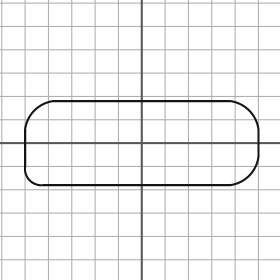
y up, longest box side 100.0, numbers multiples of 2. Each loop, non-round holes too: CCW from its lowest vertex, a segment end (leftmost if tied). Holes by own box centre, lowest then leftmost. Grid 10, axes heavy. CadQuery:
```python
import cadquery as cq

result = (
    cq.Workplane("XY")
    .moveTo(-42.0, -18.0)
    .lineTo(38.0, -18.0)
    .threePointArc((46.0, -14.0), (50.0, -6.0))
    .lineTo(50.0, 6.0)
    .threePointArc((46.0, 14.0), (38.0, 18.0))
    .lineTo(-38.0, 18.0)
    .threePointArc((-46.0, 14.0), (-50.0, 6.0))
    .lineTo(-50.0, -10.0)
    .threePointArc((-48.0, -16.0), (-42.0, -18.0))
    .close()
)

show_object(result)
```